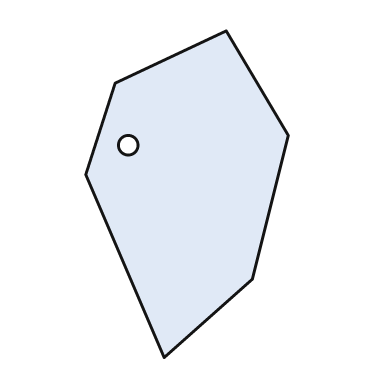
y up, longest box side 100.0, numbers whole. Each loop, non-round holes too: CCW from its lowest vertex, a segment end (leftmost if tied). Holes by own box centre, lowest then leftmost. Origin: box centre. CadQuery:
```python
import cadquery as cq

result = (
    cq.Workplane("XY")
    .moveTo(-7.0, -50.0)
    .lineTo(20.0, -26.0)
    .lineTo(31.0, 18.0)
    .lineTo(12.0, 50.0)
    .lineTo(-22.0, 34.0)
    .lineTo(-31.0, 6.0)
    .close()
    .moveTo(-18.0, 15.0)
    .circle(3.0)
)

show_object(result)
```